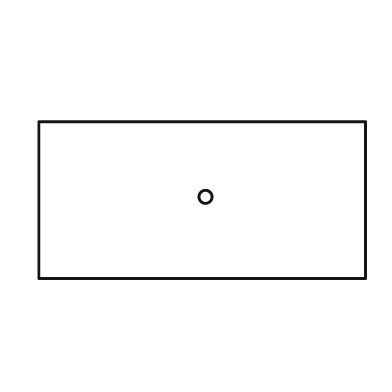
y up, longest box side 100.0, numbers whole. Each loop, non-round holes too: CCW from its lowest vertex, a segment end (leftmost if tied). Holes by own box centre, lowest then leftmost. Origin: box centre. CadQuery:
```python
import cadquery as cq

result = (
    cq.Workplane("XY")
    .moveTo(-50.0, -24.0)
    .lineTo(50.0, -24.0)
    .lineTo(50.0, 24.0)
    .lineTo(-50.0, 24.0)
    .close()
    .moveTo(1.0, 1.0)
    .circle(2.0)
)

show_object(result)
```